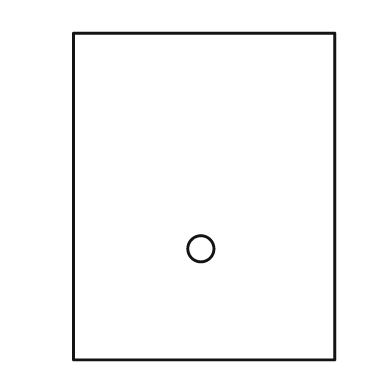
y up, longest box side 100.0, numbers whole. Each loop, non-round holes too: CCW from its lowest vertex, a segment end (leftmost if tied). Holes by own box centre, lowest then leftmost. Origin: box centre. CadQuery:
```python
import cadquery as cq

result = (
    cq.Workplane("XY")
    .moveTo(-40.0, -50.0)
    .lineTo(40.0, -50.0)
    .lineTo(40.0, 50.0)
    .lineTo(-40.0, 50.0)
    .close()
    .moveTo(-1.0, -16.0)
    .circle(4.0)
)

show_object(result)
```